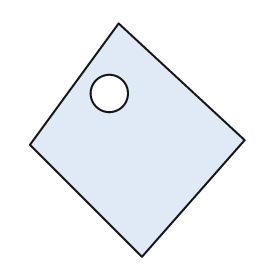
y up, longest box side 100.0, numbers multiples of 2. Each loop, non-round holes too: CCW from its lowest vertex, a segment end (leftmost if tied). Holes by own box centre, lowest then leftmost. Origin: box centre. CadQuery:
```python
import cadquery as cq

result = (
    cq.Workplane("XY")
    .moveTo(2.0, -50.0)
    .lineTo(46.0, 0.0)
    .lineTo(-8.0, 50.0)
    .lineTo(-46.0, -2.0)
    .close()
    .moveTo(-12.0, 20.0)
    .circle(8.0)
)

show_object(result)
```